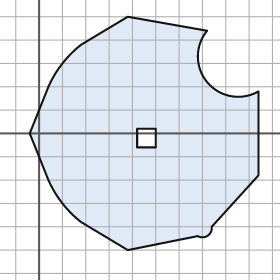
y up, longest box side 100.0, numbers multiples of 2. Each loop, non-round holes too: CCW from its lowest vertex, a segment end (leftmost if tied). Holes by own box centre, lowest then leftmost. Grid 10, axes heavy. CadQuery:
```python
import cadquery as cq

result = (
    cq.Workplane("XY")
    .moveTo(38.0, -50.0)
    .lineTo(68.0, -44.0)
    .threePointArc((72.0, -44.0), (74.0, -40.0))
    .lineTo(94.0, -18.0)
    .lineTo(94.0, 18.0)
    .threePointArc((72.0, 22.0), (72.0, 44.0))
    .lineTo(38.0, 50.0)
    .lineTo(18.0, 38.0)
    .threePointArc((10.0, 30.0), (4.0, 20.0))
    .lineTo(-4.0, 0.0)
    .lineTo(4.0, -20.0)
    .threePointArc((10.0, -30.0), (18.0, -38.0))
    .close()
    .moveTo(42.0, -6.0)
    .lineTo(50.0, -6.0)
    .lineTo(50.0, 2.0)
    .lineTo(42.0, 2.0)
    .close()
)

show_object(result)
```